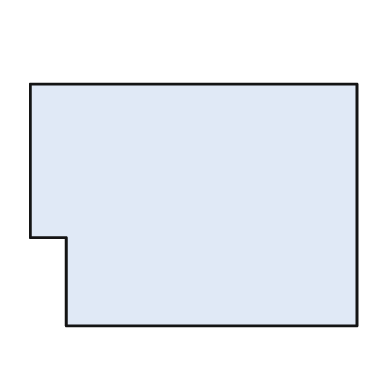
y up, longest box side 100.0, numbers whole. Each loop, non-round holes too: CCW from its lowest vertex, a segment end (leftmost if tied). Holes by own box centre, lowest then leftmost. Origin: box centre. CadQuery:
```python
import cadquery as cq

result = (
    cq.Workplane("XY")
    .moveTo(-39.0, -37.0)
    .lineTo(50.0, -37.0)
    .lineTo(50.0, 37.0)
    .lineTo(-50.0, 37.0)
    .lineTo(-50.0, -10.0)
    .lineTo(-39.0, -10.0)
    .close()
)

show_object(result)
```